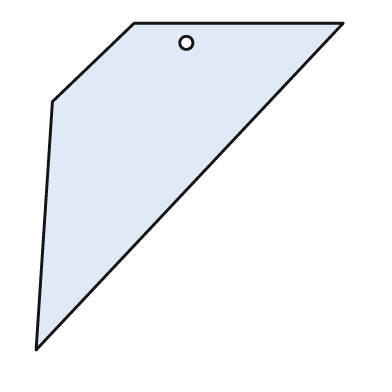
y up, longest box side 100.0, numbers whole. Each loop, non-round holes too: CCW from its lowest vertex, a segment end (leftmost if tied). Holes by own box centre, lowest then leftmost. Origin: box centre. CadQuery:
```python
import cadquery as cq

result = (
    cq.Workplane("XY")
    .moveTo(-47.0, -50.0)
    .lineTo(47.0, 50.0)
    .lineTo(-17.0, 50.0)
    .lineTo(-42.0, 26.0)
    .close()
    .moveTo(-1.0, 44.0)
    .circle(2.0)
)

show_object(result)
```